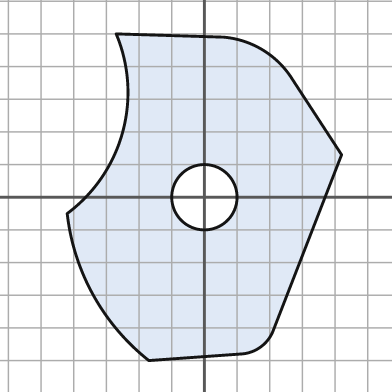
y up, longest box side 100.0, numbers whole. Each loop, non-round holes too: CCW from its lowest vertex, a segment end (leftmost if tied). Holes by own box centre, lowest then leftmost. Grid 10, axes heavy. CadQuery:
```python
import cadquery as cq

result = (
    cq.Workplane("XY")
    .moveTo(-17.0, -50.0)
    .lineTo(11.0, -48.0)
    .threePointArc((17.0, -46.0), (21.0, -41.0))
    .lineTo(42.0, 13.0)
    .lineTo(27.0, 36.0)
    .threePointArc((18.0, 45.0), (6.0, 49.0))
    .lineTo(-27.0, 50.0)
    .threePointArc((-25.0, 20.0), (-42.0, -5.0))
    .threePointArc((-34.0, -30.0), (-17.0, -50.0))
    .close()
    .moveTo(0.0, 0.0)
    .circle(10.0)
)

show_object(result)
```